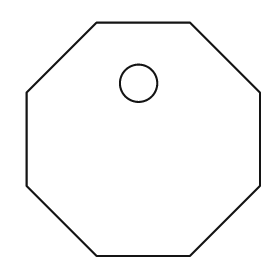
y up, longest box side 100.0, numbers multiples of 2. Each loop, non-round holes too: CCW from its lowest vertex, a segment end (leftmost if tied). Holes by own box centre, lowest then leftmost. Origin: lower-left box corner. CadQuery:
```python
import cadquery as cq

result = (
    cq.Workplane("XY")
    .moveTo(30.0, 0.0)
    .lineTo(70.0, 0.0)
    .lineTo(100.0, 30.0)
    .lineTo(100.0, 70.0)
    .lineTo(70.0, 100.0)
    .lineTo(30.0, 100.0)
    .lineTo(0.0, 70.0)
    .lineTo(0.0, 30.0)
    .close()
    .moveTo(48.0, 74.0)
    .circle(8.0)
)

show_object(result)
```